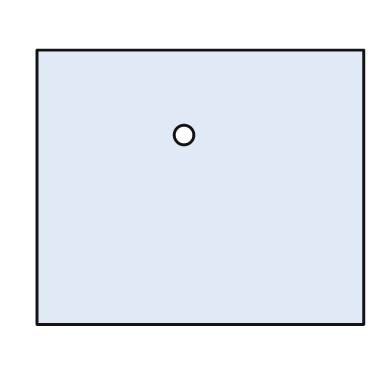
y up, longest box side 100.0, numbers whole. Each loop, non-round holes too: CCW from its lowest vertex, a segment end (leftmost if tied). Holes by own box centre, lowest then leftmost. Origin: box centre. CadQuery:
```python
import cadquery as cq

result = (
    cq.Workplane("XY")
    .moveTo(-50.0, -42.0)
    .lineTo(50.0, -42.0)
    .lineTo(50.0, 42.0)
    .lineTo(-50.0, 42.0)
    .close()
    .moveTo(-5.0, 16.0)
    .circle(3.0)
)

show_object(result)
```